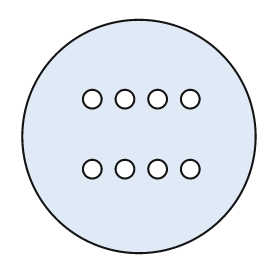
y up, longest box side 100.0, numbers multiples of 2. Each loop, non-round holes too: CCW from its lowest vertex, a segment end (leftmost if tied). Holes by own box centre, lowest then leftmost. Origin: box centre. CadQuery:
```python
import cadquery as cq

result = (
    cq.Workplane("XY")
    .moveTo(0.0, 0.0)
    .circle(50.0)
    .moveTo(-20.0, -14.0)
    .circle(4.0)
    .moveTo(-6.0, -14.0)
    .circle(4.0)
    .moveTo(8.0, -14.0)
    .circle(4.0)
    .moveTo(22.0, -14.0)
    .circle(4.0)
    .moveTo(-20.0, 16.0)
    .circle(4.0)
    .moveTo(-6.0, 16.0)
    .circle(4.0)
    .moveTo(8.0, 16.0)
    .circle(4.0)
    .moveTo(22.0, 16.0)
    .circle(4.0)
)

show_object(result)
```